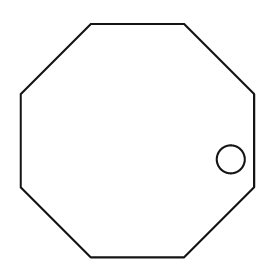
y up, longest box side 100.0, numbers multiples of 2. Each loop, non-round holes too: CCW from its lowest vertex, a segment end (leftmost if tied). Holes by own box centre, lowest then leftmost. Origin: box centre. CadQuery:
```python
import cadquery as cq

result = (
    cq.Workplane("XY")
    .moveTo(-20.0, -50.0)
    .lineTo(20.0, -50.0)
    .lineTo(50.0, -20.0)
    .lineTo(50.0, 20.0)
    .lineTo(20.0, 50.0)
    .lineTo(-20.0, 50.0)
    .lineTo(-50.0, 20.0)
    .lineTo(-50.0, -20.0)
    .close()
    .moveTo(40.0, -8.0)
    .circle(6.0)
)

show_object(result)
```